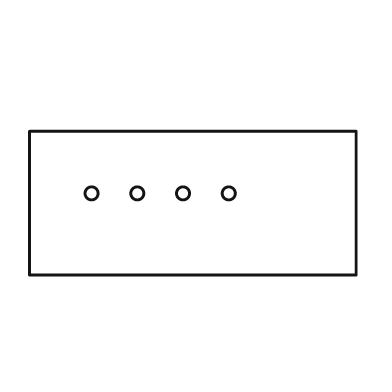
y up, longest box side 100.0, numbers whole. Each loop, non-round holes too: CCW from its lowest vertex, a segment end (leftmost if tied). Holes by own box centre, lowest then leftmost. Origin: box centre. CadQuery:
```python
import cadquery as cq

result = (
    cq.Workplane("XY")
    .moveTo(-50.0, -22.0)
    .lineTo(50.0, -22.0)
    .lineTo(50.0, 22.0)
    .lineTo(-50.0, 22.0)
    .close()
    .moveTo(-31.0, 3.0)
    .circle(2.0)
    .moveTo(-17.0, 3.0)
    .circle(2.0)
    .moveTo(-3.0, 3.0)
    .circle(2.0)
    .moveTo(11.0, 3.0)
    .circle(2.0)
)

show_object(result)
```